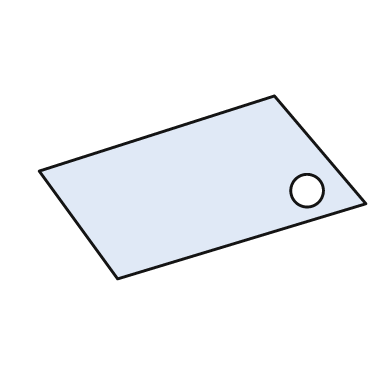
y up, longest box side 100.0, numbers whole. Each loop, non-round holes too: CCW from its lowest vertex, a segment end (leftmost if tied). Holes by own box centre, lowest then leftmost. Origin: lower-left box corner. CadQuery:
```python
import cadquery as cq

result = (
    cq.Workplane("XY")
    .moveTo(24.0, 0.0)
    .lineTo(100.0, 23.0)
    .lineTo(72.0, 56.0)
    .lineTo(0.0, 33.0)
    .close()
    .moveTo(82.0, 27.0)
    .circle(5.0)
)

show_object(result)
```